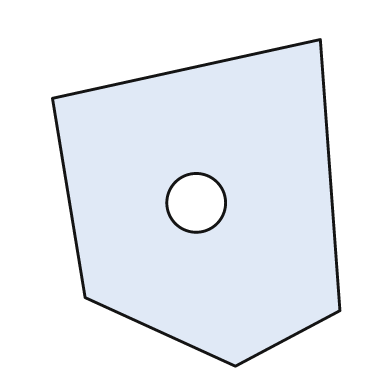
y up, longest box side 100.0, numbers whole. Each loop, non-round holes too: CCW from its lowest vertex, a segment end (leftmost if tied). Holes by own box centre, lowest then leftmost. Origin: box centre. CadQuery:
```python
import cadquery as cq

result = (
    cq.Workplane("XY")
    .moveTo(12.0, -50.0)
    .lineTo(44.0, -33.0)
    .lineTo(38.0, 50.0)
    .lineTo(-44.0, 32.0)
    .lineTo(-34.0, -29.0)
    .close()
    .moveTo(0.0, 0.0)
    .circle(9.0)
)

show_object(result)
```